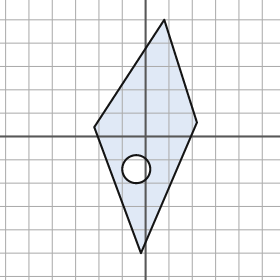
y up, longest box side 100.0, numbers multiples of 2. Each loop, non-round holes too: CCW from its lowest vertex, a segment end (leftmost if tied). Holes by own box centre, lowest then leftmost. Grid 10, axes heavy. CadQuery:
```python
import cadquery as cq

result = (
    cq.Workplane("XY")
    .moveTo(-2.0, -50.0)
    .lineTo(22.0, 6.0)
    .lineTo(8.0, 50.0)
    .lineTo(-22.0, 4.0)
    .close()
    .moveTo(-4.0, -14.0)
    .circle(6.0)
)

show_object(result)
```